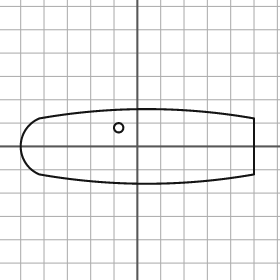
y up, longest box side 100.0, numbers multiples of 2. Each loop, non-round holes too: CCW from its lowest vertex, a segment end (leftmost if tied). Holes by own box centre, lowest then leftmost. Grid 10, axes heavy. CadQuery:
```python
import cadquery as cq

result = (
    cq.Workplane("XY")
    .moveTo(-42.0, -12.0)
    .threePointArc((4.0, -16.0), (50.0, -12.0))
    .lineTo(50.0, 12.0)
    .threePointArc((4.0, 16.0), (-42.0, 12.0))
    .threePointArc((-50.0, 0.0), (-42.0, -12.0))
    .close()
    .moveTo(-8.0, 8.0)
    .circle(2.0)
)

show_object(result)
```